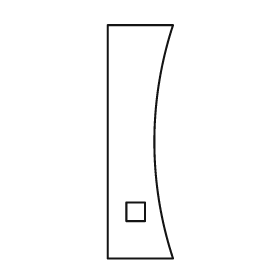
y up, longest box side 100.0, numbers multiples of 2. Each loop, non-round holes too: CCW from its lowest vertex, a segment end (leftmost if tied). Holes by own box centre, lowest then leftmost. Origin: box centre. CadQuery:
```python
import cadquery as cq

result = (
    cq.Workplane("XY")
    .moveTo(-14.0, -50.0)
    .lineTo(14.0, -50.0)
    .threePointArc((6.0, 0.0), (14.0, 50.0))
    .lineTo(-14.0, 50.0)
    .close()
    .moveTo(-6.0, -34.0)
    .lineTo(2.0, -34.0)
    .lineTo(2.0, -26.0)
    .lineTo(-6.0, -26.0)
    .close()
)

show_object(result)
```